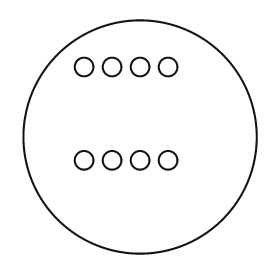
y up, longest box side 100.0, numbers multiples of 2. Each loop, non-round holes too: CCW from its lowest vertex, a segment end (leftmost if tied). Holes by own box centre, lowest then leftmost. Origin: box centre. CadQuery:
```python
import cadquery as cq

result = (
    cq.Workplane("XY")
    .moveTo(0.0, 0.0)
    .circle(50.0)
    .moveTo(-24.0, -10.0)
    .circle(4.0)
    .moveTo(-12.0, -10.0)
    .circle(4.0)
    .moveTo(0.0, -10.0)
    .circle(4.0)
    .moveTo(12.0, -10.0)
    .circle(4.0)
    .moveTo(-24.0, 30.0)
    .circle(4.0)
    .moveTo(-12.0, 30.0)
    .circle(4.0)
    .moveTo(0.0, 30.0)
    .circle(4.0)
    .moveTo(12.0, 30.0)
    .circle(4.0)
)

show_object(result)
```